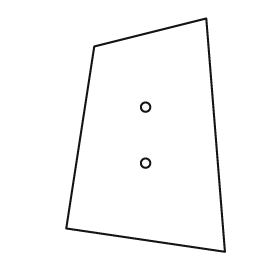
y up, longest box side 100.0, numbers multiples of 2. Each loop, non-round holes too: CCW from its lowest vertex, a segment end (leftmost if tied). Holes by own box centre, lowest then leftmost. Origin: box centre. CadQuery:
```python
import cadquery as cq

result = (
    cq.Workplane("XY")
    .moveTo(34.0, -50.0)
    .lineTo(26.0, 50.0)
    .lineTo(-22.0, 38.0)
    .lineTo(-34.0, -40.0)
    .close()
    .moveTo(0.0, -12.0)
    .circle(2.0)
    .moveTo(0.0, 12.0)
    .circle(2.0)
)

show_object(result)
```